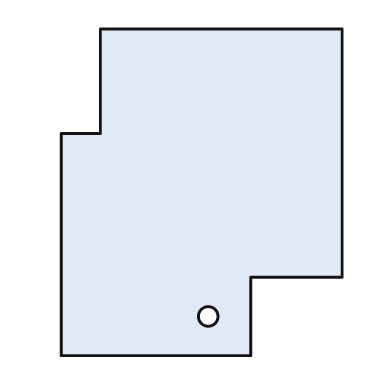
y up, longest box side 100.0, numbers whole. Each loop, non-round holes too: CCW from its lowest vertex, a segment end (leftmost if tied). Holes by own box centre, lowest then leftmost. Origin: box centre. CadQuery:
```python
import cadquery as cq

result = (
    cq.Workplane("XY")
    .moveTo(-43.0, -50.0)
    .lineTo(15.0, -50.0)
    .lineTo(15.0, -26.0)
    .lineTo(43.0, -26.0)
    .lineTo(43.0, 50.0)
    .lineTo(-31.0, 50.0)
    .lineTo(-31.0, 18.0)
    .lineTo(-43.0, 18.0)
    .close()
    .moveTo(2.0, -38.0)
    .circle(3.0)
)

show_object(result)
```